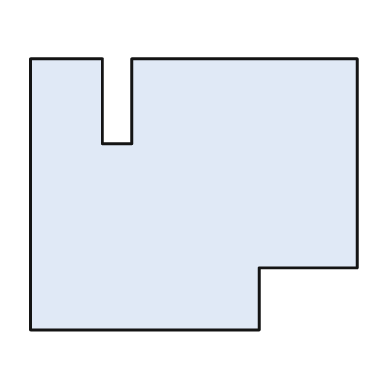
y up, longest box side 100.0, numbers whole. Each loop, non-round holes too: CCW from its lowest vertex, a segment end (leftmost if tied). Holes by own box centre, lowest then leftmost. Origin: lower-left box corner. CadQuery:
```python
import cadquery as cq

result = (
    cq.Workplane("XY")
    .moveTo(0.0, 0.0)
    .lineTo(70.0, 0.0)
    .lineTo(70.0, 19.0)
    .lineTo(100.0, 19.0)
    .lineTo(100.0, 83.0)
    .lineTo(31.0, 83.0)
    .lineTo(31.0, 57.0)
    .lineTo(22.0, 57.0)
    .lineTo(22.0, 83.0)
    .lineTo(0.0, 83.0)
    .close()
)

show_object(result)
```